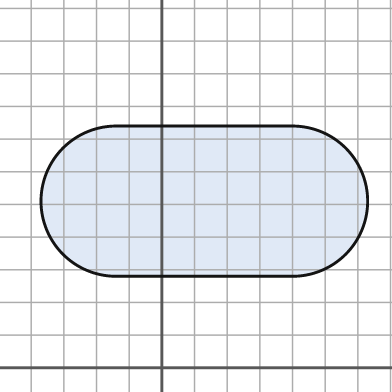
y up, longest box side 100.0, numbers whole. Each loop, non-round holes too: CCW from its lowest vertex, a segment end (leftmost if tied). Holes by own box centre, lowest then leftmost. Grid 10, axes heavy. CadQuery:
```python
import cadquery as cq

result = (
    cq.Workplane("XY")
    .moveTo(-14.0, 28.0)
    .lineTo(40.0, 28.0)
    .threePointArc((63.0, 51.0), (40.0, 74.0))
    .lineTo(-14.0, 74.0)
    .threePointArc((-37.0, 51.0), (-14.0, 28.0))
    .close()
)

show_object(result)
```